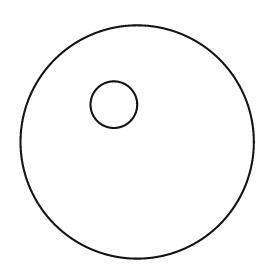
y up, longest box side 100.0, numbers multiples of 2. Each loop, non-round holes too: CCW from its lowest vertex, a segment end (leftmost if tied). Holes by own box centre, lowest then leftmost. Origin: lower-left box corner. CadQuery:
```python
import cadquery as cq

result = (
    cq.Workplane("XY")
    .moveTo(50.0, 50.0)
    .circle(50.0)
    .moveTo(40.0, 66.0)
    .circle(10.0)
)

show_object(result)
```